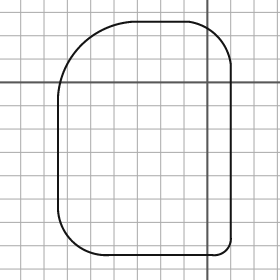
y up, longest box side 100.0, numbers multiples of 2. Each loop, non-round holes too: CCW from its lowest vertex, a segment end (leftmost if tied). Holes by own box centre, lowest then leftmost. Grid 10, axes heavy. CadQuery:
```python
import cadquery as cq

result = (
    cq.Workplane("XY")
    .moveTo(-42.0, -74.0)
    .lineTo(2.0, -74.0)
    .threePointArc((8.0, -72.0), (10.0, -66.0))
    .lineTo(10.0, 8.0)
    .threePointArc((4.0, 20.0), (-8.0, 26.0))
    .lineTo(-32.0, 26.0)
    .threePointArc((-54.0, 16.0), (-64.0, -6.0))
    .lineTo(-64.0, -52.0)
    .threePointArc((-58.0, -68.0), (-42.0, -74.0))
    .close()
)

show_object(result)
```